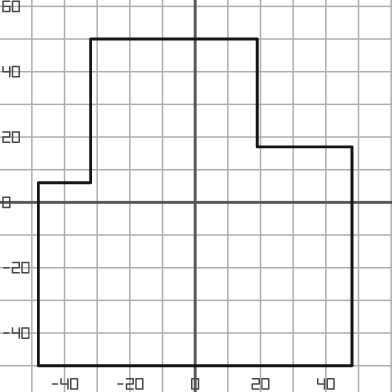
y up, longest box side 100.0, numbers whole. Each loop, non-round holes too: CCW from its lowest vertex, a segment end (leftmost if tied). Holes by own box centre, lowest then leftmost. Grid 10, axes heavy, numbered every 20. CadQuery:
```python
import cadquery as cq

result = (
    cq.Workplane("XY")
    .moveTo(-48.0, -50.0)
    .lineTo(48.0, -50.0)
    .lineTo(48.0, 17.0)
    .lineTo(19.0, 17.0)
    .lineTo(19.0, 50.0)
    .lineTo(-32.0, 50.0)
    .lineTo(-32.0, 6.0)
    .lineTo(-48.0, 6.0)
    .close()
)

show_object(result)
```